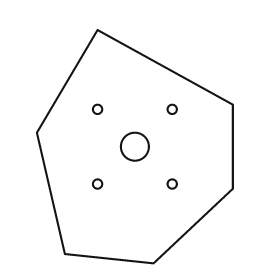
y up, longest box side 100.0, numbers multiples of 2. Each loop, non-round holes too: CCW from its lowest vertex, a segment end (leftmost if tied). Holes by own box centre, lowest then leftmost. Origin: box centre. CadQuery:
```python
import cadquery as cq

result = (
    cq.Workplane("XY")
    .moveTo(8.0, -50.0)
    .lineTo(42.0, -18.0)
    .lineTo(42.0, 18.0)
    .lineTo(-16.0, 50.0)
    .lineTo(-42.0, 6.0)
    .lineTo(-30.0, -46.0)
    .close()
    .moveTo(-16.0, -16.0)
    .circle(2.0)
    .moveTo(16.0, -16.0)
    .circle(2.0)
    .moveTo(0.0, 0.0)
    .circle(6.0)
    .moveTo(-16.0, 16.0)
    .circle(2.0)
    .moveTo(16.0, 16.0)
    .circle(2.0)
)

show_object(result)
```